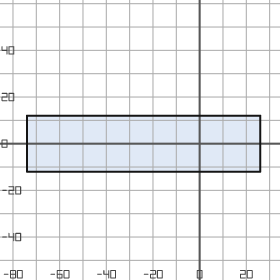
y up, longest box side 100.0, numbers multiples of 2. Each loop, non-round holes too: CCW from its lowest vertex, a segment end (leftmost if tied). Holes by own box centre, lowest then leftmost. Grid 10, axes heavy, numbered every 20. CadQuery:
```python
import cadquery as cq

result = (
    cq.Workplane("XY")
    .moveTo(-74.0, -12.0)
    .lineTo(26.0, -12.0)
    .lineTo(26.0, 12.0)
    .lineTo(-74.0, 12.0)
    .close()
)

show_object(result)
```